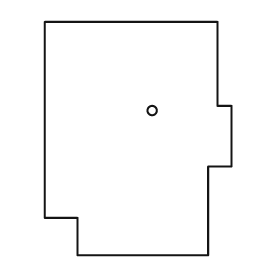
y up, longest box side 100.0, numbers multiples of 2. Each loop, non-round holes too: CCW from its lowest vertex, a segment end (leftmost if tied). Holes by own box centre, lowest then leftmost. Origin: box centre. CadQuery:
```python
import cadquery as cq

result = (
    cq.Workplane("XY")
    .moveTo(-26.0, -50.0)
    .lineTo(30.0, -50.0)
    .lineTo(30.0, -12.0)
    .lineTo(40.0, -12.0)
    .lineTo(40.0, 14.0)
    .lineTo(34.0, 14.0)
    .lineTo(34.0, 50.0)
    .lineTo(-40.0, 50.0)
    .lineTo(-40.0, -34.0)
    .lineTo(-26.0, -34.0)
    .close()
    .moveTo(6.0, 12.0)
    .circle(2.0)
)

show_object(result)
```